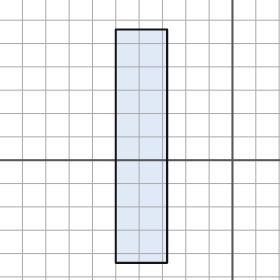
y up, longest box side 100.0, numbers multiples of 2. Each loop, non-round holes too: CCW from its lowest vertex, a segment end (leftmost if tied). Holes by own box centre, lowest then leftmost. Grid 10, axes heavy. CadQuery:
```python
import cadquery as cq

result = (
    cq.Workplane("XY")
    .moveTo(-50.0, -44.0)
    .lineTo(-28.0, -44.0)
    .lineTo(-28.0, 56.0)
    .lineTo(-50.0, 56.0)
    .close()
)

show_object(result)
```